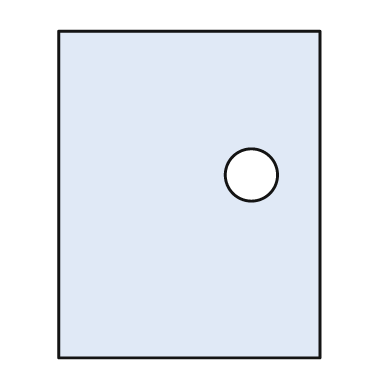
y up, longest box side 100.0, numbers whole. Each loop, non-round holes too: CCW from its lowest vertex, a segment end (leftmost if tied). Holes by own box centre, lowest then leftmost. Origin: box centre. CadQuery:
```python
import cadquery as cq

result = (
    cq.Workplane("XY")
    .moveTo(-40.0, -50.0)
    .lineTo(40.0, -50.0)
    .lineTo(40.0, 50.0)
    .lineTo(-40.0, 50.0)
    .close()
    .moveTo(19.0, 6.0)
    .circle(8.0)
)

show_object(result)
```